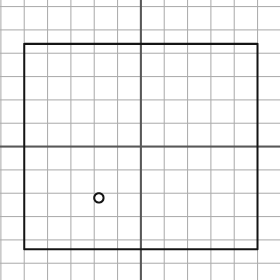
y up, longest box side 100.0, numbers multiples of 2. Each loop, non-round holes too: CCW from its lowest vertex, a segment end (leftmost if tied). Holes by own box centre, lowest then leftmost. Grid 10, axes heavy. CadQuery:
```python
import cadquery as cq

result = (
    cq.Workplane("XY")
    .moveTo(-50.0, -44.0)
    .lineTo(50.0, -44.0)
    .lineTo(50.0, 44.0)
    .lineTo(-50.0, 44.0)
    .close()
    .moveTo(-18.0, -22.0)
    .circle(2.0)
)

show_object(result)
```